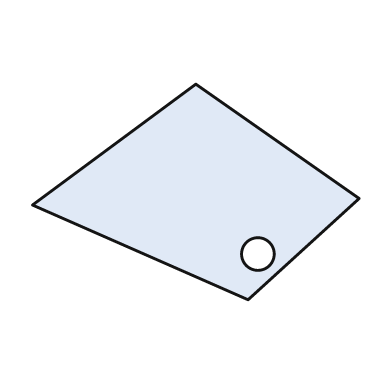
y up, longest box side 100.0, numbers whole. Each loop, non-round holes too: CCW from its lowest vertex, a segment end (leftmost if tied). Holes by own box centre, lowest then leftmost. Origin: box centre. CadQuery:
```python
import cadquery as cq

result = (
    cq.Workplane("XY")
    .moveTo(16.0, -33.0)
    .lineTo(50.0, -2.0)
    .lineTo(0.0, 33.0)
    .lineTo(-50.0, -4.0)
    .close()
    .moveTo(19.0, -19.0)
    .circle(5.0)
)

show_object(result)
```